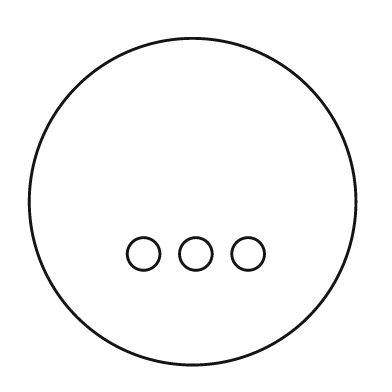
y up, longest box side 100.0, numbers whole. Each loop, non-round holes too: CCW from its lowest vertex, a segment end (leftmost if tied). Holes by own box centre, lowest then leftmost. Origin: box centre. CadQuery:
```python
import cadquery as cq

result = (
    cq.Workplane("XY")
    .moveTo(0.0, 0.0)
    .circle(50.0)
    .moveTo(-15.0, -16.0)
    .circle(5.0)
    .moveTo(1.0, -16.0)
    .circle(5.0)
    .moveTo(17.0, -16.0)
    .circle(5.0)
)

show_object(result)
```